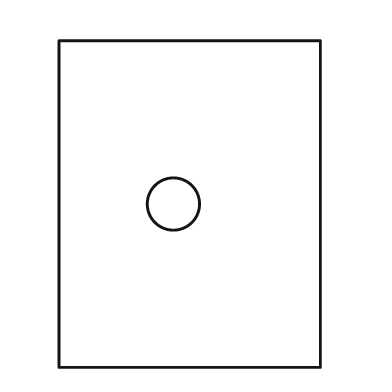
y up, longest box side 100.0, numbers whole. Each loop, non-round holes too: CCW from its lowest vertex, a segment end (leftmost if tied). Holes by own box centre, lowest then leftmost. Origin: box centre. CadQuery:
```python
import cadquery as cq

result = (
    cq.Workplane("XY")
    .moveTo(-40.0, -50.0)
    .lineTo(40.0, -50.0)
    .lineTo(40.0, 50.0)
    .lineTo(-40.0, 50.0)
    .close()
    .moveTo(-5.0, 0.0)
    .circle(8.0)
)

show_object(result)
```